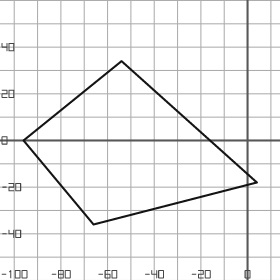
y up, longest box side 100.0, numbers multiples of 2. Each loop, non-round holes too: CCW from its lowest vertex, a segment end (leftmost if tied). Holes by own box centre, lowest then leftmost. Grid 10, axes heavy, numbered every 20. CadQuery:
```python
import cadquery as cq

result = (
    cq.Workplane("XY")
    .moveTo(-66.0, -36.0)
    .lineTo(4.0, -18.0)
    .lineTo(-54.0, 34.0)
    .lineTo(-96.0, 0.0)
    .close()
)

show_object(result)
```